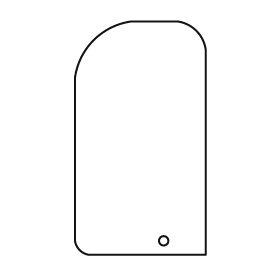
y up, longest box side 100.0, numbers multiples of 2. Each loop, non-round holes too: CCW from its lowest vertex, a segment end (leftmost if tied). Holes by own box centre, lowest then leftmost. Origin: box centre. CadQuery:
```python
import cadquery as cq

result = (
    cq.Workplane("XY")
    .moveTo(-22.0, -50.0)
    .lineTo(28.0, -50.0)
    .lineTo(28.0, 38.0)
    .threePointArc((24.0, 46.0), (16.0, 50.0))
    .lineTo(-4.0, 50.0)
    .threePointArc((-20.0, 42.0), (-28.0, 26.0))
    .lineTo(-28.0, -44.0)
    .threePointArc((-26.0, -48.0), (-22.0, -50.0))
    .close()
    .moveTo(10.0, -44.0)
    .circle(2.0)
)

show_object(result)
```